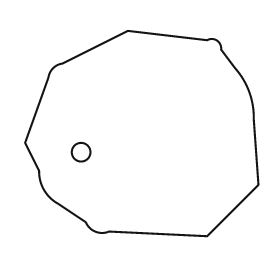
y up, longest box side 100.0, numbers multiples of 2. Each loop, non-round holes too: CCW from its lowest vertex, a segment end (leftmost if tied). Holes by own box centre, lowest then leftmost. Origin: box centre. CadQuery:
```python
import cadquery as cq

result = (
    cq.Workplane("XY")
    .moveTo(28.0, -44.0)
    .lineTo(50.0, -22.0)
    .lineTo(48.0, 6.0)
    .threePointArc((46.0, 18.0), (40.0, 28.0))
    .lineTo(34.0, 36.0)
    .threePointArc((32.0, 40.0), (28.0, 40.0))
    .lineTo(-6.0, 44.0)
    .lineTo(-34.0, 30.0)
    .threePointArc((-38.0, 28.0), (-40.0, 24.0))
    .lineTo(-50.0, -4.0)
    .lineTo(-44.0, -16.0)
    .threePointArc((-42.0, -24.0), (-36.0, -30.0))
    .lineTo(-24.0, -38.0)
    .threePointArc((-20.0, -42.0), (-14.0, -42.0))
    .close()
    .moveTo(-26.0, -8.0)
    .circle(4.0)
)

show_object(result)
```